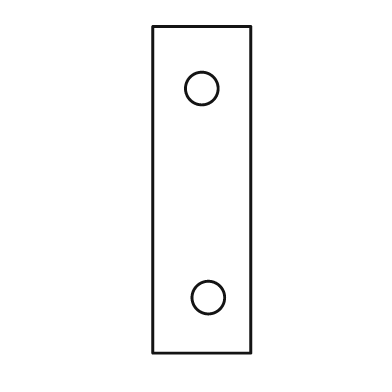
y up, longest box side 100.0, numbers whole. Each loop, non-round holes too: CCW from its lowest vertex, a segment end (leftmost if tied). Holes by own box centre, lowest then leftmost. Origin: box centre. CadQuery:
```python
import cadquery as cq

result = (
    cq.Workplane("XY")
    .moveTo(-15.0, -50.0)
    .lineTo(15.0, -50.0)
    .lineTo(15.0, 50.0)
    .lineTo(-15.0, 50.0)
    .close()
    .moveTo(2.0, -33.0)
    .circle(5.0)
    .moveTo(0.0, 31.0)
    .circle(5.0)
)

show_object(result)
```